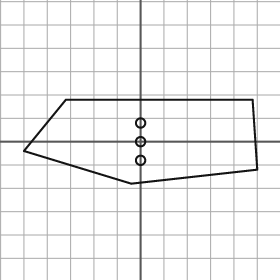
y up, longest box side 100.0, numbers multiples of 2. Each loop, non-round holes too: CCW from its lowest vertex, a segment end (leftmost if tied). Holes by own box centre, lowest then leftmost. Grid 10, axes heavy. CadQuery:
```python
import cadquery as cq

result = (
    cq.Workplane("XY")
    .moveTo(-4.0, -18.0)
    .lineTo(50.0, -12.0)
    .lineTo(48.0, 18.0)
    .lineTo(-32.0, 18.0)
    .lineTo(-50.0, -4.0)
    .close()
    .moveTo(0.0, -8.0)
    .circle(2.0)
    .moveTo(0.0, 0.0)
    .circle(2.0)
    .moveTo(0.0, 8.0)
    .circle(2.0)
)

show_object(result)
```